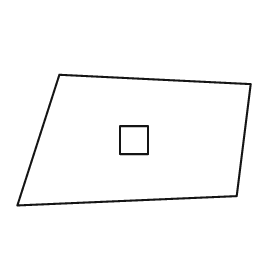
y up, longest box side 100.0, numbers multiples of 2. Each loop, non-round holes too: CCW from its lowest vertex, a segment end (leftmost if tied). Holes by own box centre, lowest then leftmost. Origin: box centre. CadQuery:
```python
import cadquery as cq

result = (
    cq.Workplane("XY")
    .moveTo(-50.0, -28.0)
    .lineTo(44.0, -24.0)
    .lineTo(50.0, 24.0)
    .lineTo(-32.0, 28.0)
    .close()
    .moveTo(-6.0, -6.0)
    .lineTo(6.0, -6.0)
    .lineTo(6.0, 6.0)
    .lineTo(-6.0, 6.0)
    .close()
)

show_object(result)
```